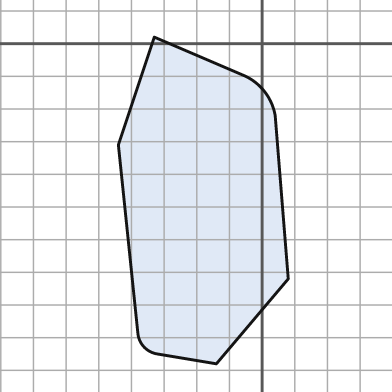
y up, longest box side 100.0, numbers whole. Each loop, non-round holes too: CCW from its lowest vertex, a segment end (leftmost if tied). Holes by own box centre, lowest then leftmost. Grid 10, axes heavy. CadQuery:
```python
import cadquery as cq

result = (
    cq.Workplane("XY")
    .moveTo(-14.0, -98.0)
    .lineTo(8.0, -72.0)
    .lineTo(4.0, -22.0)
    .threePointArc((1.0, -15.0), (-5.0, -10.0))
    .lineTo(-33.0, 2.0)
    .lineTo(-44.0, -31.0)
    .lineTo(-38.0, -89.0)
    .threePointArc((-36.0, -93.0), (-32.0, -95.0))
    .close()
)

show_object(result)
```